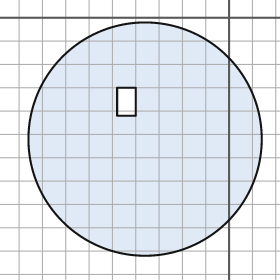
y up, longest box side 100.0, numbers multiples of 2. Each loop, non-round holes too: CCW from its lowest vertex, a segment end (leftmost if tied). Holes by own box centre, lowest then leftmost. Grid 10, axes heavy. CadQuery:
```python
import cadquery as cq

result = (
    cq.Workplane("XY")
    .moveTo(-36.0, -52.0)
    .circle(50.0)
    .moveTo(-48.0, -42.0)
    .lineTo(-40.0, -42.0)
    .lineTo(-40.0, -30.0)
    .lineTo(-48.0, -30.0)
    .close()
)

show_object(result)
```